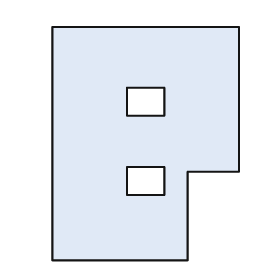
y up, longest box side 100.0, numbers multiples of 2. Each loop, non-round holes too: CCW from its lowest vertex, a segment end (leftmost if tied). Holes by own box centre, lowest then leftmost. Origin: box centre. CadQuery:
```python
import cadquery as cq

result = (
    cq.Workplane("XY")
    .moveTo(-40.0, -50.0)
    .lineTo(18.0, -50.0)
    .lineTo(18.0, -12.0)
    .lineTo(40.0, -12.0)
    .lineTo(40.0, 50.0)
    .lineTo(-40.0, 50.0)
    .close()
    .moveTo(-8.0, -22.0)
    .lineTo(8.0, -22.0)
    .lineTo(8.0, -10.0)
    .lineTo(-8.0, -10.0)
    .close()
    .moveTo(-8.0, 12.0)
    .lineTo(8.0, 12.0)
    .lineTo(8.0, 24.0)
    .lineTo(-8.0, 24.0)
    .close()
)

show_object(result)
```